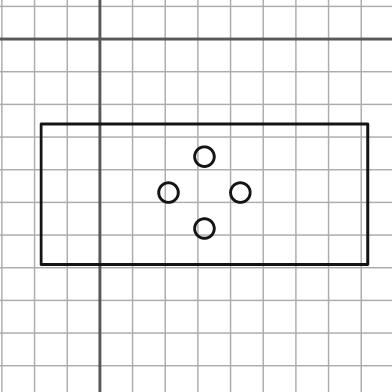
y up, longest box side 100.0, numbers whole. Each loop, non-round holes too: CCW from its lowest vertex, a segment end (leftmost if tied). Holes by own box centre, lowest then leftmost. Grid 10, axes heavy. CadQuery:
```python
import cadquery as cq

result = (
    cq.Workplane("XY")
    .moveTo(-18.0, -69.0)
    .lineTo(82.0, -69.0)
    .lineTo(82.0, -26.0)
    .lineTo(-18.0, -26.0)
    .close()
    .moveTo(32.0, -58.0)
    .circle(3.0)
    .moveTo(21.0, -47.0)
    .circle(3.0)
    .moveTo(43.0, -47.0)
    .circle(3.0)
    .moveTo(32.0, -36.0)
    .circle(3.0)
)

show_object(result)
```